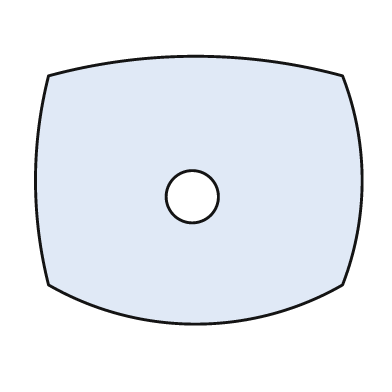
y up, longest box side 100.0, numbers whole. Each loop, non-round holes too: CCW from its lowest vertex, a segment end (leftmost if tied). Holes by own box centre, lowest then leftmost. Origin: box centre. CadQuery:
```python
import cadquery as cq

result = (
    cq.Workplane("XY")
    .moveTo(-46.0, -29.0)
    .threePointArc((-1.0, -41.0), (44.0, -29.0))
    .threePointArc((50.0, 3.0), (44.0, 35.0))
    .threePointArc((-1.0, 41.0), (-46.0, 35.0))
    .threePointArc((-50.0, 3.0), (-46.0, -29.0))
    .close()
    .moveTo(-2.0, -2.0)
    .circle(8.0)
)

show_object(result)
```